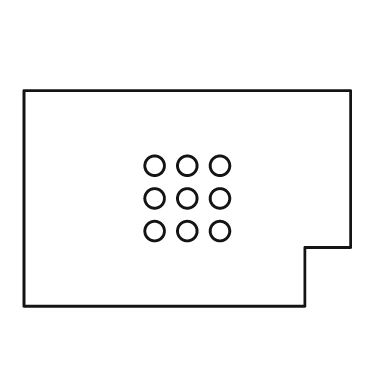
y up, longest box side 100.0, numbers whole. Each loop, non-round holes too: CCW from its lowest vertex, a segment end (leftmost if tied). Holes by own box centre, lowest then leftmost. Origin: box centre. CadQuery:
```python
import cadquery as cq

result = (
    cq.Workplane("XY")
    .moveTo(-50.0, -33.0)
    .lineTo(36.0, -33.0)
    .lineTo(36.0, -15.0)
    .lineTo(50.0, -15.0)
    .lineTo(50.0, 33.0)
    .lineTo(-50.0, 33.0)
    .close()
    .moveTo(-10.0, -10.0)
    .circle(3.0)
    .moveTo(0.0, -10.0)
    .circle(3.0)
    .moveTo(10.0, -10.0)
    .circle(3.0)
    .moveTo(-10.0, 0.0)
    .circle(3.0)
    .moveTo(0.0, 0.0)
    .circle(3.0)
    .moveTo(10.0, 0.0)
    .circle(3.0)
    .moveTo(-10.0, 10.0)
    .circle(3.0)
    .moveTo(0.0, 10.0)
    .circle(3.0)
    .moveTo(10.0, 10.0)
    .circle(3.0)
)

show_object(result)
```